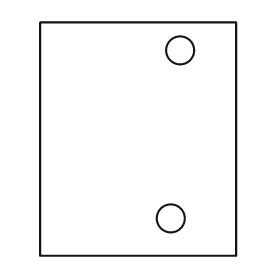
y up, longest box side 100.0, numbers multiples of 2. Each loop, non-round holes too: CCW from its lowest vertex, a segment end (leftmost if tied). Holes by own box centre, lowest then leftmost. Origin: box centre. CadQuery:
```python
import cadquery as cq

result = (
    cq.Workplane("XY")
    .moveTo(-42.0, -50.0)
    .lineTo(42.0, -50.0)
    .lineTo(42.0, 50.0)
    .lineTo(-42.0, 50.0)
    .close()
    .moveTo(14.0, -34.0)
    .circle(6.0)
    .moveTo(18.0, 38.0)
    .circle(6.0)
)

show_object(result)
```